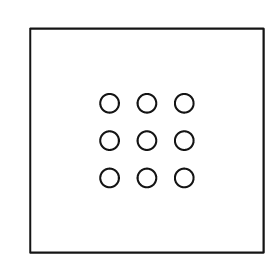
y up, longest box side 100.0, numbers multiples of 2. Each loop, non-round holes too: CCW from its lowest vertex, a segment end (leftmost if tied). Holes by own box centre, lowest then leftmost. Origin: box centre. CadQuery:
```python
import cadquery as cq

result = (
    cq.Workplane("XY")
    .moveTo(-50.0, -48.0)
    .lineTo(50.0, -48.0)
    .lineTo(50.0, 48.0)
    .lineTo(-50.0, 48.0)
    .close()
    .moveTo(-16.0, -16.0)
    .circle(4.0)
    .moveTo(0.0, -16.0)
    .circle(4.0)
    .moveTo(16.0, -16.0)
    .circle(4.0)
    .moveTo(-16.0, 0.0)
    .circle(4.0)
    .moveTo(0.0, 0.0)
    .circle(4.0)
    .moveTo(16.0, 0.0)
    .circle(4.0)
    .moveTo(-16.0, 16.0)
    .circle(4.0)
    .moveTo(0.0, 16.0)
    .circle(4.0)
    .moveTo(16.0, 16.0)
    .circle(4.0)
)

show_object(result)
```